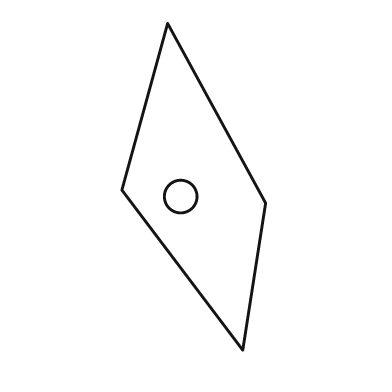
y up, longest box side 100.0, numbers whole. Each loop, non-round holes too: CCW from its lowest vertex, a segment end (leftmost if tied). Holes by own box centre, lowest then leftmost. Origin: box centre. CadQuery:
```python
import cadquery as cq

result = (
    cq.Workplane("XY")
    .moveTo(15.0, -50.0)
    .lineTo(22.0, -5.0)
    .lineTo(-8.0, 50.0)
    .lineTo(-22.0, -1.0)
    .close()
    .moveTo(-4.0, -3.0)
    .circle(5.0)
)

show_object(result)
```